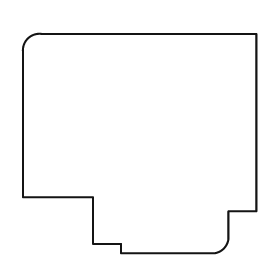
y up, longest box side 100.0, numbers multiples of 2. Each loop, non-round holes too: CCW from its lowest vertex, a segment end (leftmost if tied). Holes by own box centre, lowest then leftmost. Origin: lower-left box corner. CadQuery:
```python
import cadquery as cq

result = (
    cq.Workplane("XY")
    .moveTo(42.0, 0.0)
    .lineTo(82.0, 0.0)
    .threePointArc((86.0, 2.0), (88.0, 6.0))
    .lineTo(88.0, 18.0)
    .lineTo(100.0, 18.0)
    .lineTo(100.0, 94.0)
    .lineTo(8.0, 94.0)
    .threePointArc((2.0, 92.0), (0.0, 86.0))
    .lineTo(0.0, 24.0)
    .lineTo(30.0, 24.0)
    .lineTo(30.0, 4.0)
    .lineTo(42.0, 4.0)
    .close()
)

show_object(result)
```